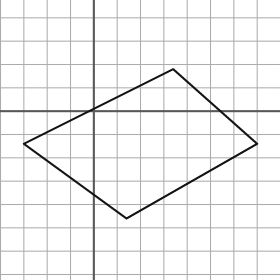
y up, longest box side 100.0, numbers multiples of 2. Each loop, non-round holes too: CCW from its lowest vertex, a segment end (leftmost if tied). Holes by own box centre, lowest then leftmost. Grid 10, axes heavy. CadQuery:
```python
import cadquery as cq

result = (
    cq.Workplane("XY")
    .moveTo(14.0, -46.0)
    .lineTo(70.0, -14.0)
    .lineTo(34.0, 18.0)
    .lineTo(-30.0, -14.0)
    .close()
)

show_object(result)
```